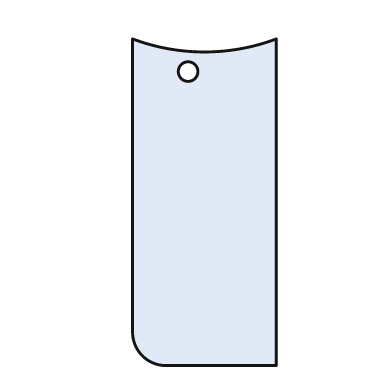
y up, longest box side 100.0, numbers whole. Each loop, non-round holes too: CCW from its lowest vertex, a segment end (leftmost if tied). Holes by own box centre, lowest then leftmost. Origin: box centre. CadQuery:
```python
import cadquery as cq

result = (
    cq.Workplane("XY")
    .moveTo(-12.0, -50.0)
    .lineTo(22.0, -50.0)
    .lineTo(22.0, 50.0)
    .threePointArc((0.0, 46.0), (-22.0, 50.0))
    .lineTo(-22.0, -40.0)
    .threePointArc((-19.0, -47.0), (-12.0, -50.0))
    .close()
    .moveTo(-5.0, 40.0)
    .circle(3.0)
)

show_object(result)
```